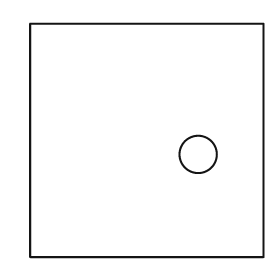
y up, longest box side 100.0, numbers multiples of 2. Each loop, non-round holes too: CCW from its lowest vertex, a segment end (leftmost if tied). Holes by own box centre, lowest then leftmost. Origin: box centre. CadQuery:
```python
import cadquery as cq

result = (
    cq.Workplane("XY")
    .moveTo(-50.0, -50.0)
    .lineTo(50.0, -50.0)
    .lineTo(50.0, 50.0)
    .lineTo(-50.0, 50.0)
    .close()
    .moveTo(22.0, -6.0)
    .circle(8.0)
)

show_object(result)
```